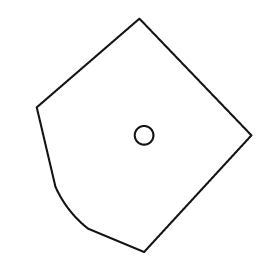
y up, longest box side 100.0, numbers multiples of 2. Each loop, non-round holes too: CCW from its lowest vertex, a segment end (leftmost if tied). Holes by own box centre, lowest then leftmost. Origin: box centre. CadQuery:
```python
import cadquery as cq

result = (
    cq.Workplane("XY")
    .moveTo(0.0, -50.0)
    .lineTo(46.0, 0.0)
    .lineTo(-2.0, 50.0)
    .lineTo(-46.0, 12.0)
    .lineTo(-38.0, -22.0)
    .threePointArc((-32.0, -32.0), (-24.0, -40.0))
    .close()
    .moveTo(0.0, 0.0)
    .circle(4.0)
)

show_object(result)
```